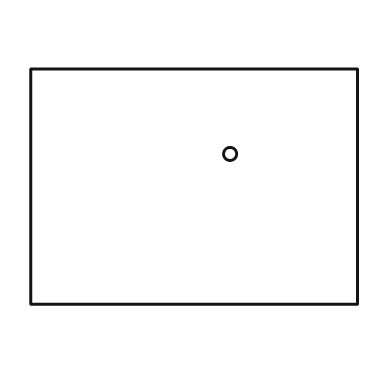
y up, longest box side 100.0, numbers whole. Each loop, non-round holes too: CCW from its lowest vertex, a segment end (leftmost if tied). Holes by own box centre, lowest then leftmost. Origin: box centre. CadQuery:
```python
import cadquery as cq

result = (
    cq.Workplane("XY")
    .moveTo(-50.0, -36.0)
    .lineTo(50.0, -36.0)
    .lineTo(50.0, 36.0)
    .lineTo(-50.0, 36.0)
    .close()
    .moveTo(11.0, 10.0)
    .circle(2.0)
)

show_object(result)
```